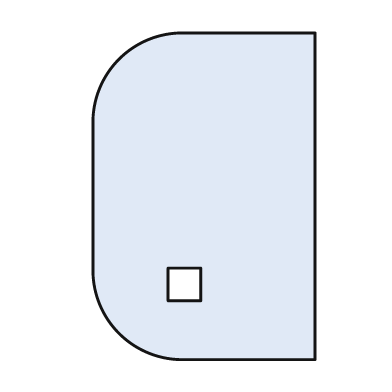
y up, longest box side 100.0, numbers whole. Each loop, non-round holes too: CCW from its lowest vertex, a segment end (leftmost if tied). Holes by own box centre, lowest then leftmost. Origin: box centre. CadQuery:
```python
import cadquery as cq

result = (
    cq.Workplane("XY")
    .moveTo(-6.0, -50.0)
    .lineTo(34.0, -50.0)
    .lineTo(34.0, 50.0)
    .lineTo(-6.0, 50.0)
    .threePointArc((-26.0, 42.0), (-34.0, 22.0))
    .lineTo(-34.0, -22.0)
    .threePointArc((-26.0, -42.0), (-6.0, -50.0))
    .close()
    .moveTo(-11.0, -32.0)
    .lineTo(-1.0, -32.0)
    .lineTo(-1.0, -22.0)
    .lineTo(-11.0, -22.0)
    .close()
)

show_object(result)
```